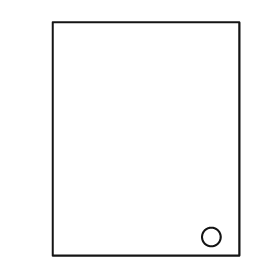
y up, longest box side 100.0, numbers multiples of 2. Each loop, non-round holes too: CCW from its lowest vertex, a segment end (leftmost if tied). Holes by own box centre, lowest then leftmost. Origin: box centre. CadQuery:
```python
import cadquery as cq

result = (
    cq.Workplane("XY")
    .moveTo(-40.0, -50.0)
    .lineTo(40.0, -50.0)
    .lineTo(40.0, 50.0)
    .lineTo(-40.0, 50.0)
    .close()
    .moveTo(28.0, -42.0)
    .circle(4.0)
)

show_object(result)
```